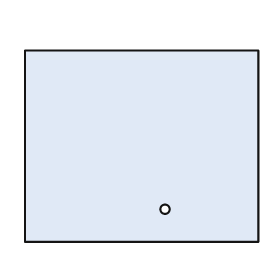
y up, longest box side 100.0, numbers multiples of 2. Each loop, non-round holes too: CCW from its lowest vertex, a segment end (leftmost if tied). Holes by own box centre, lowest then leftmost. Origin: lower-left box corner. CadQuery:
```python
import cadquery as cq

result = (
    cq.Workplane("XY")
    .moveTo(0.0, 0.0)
    .lineTo(100.0, 0.0)
    .lineTo(100.0, 82.0)
    .lineTo(0.0, 82.0)
    .close()
    .moveTo(60.0, 14.0)
    .circle(2.0)
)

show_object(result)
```